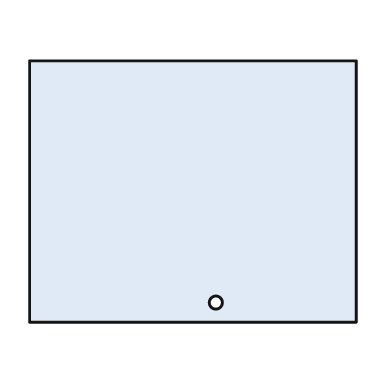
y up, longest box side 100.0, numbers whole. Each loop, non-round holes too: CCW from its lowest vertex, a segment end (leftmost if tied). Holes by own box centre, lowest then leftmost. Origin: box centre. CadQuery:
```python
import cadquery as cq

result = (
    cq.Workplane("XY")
    .moveTo(-50.0, -40.0)
    .lineTo(50.0, -40.0)
    .lineTo(50.0, 40.0)
    .lineTo(-50.0, 40.0)
    .close()
    .moveTo(7.0, -34.0)
    .circle(2.0)
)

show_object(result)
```